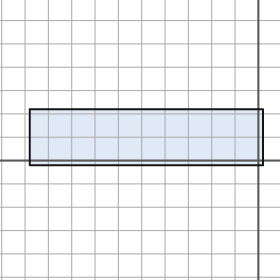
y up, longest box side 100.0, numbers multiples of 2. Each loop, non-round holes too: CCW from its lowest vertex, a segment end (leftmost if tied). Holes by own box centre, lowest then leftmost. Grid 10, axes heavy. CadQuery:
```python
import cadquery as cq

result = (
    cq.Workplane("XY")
    .moveTo(-98.0, -2.0)
    .lineTo(2.0, -2.0)
    .lineTo(2.0, 22.0)
    .lineTo(-98.0, 22.0)
    .close()
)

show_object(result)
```